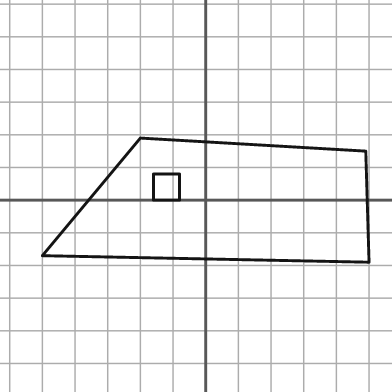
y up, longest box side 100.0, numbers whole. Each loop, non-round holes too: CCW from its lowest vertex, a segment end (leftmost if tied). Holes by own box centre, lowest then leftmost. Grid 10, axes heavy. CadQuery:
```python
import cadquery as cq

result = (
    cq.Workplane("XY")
    .moveTo(50.0, -19.0)
    .lineTo(49.0, 15.0)
    .lineTo(-20.0, 19.0)
    .lineTo(-50.0, -17.0)
    .close()
    .moveTo(-16.0, 0.0)
    .lineTo(-8.0, 0.0)
    .lineTo(-8.0, 8.0)
    .lineTo(-16.0, 8.0)
    .close()
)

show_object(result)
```